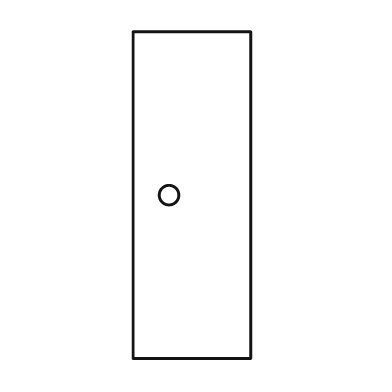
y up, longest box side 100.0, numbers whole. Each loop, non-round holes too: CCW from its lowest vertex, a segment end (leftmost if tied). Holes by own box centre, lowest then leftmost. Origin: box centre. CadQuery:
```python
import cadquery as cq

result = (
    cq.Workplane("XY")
    .moveTo(-18.0, -50.0)
    .lineTo(18.0, -50.0)
    .lineTo(18.0, 50.0)
    .lineTo(-18.0, 50.0)
    .close()
    .moveTo(-7.0, 0.0)
    .circle(3.0)
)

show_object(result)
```